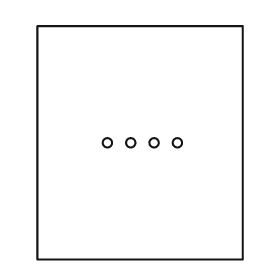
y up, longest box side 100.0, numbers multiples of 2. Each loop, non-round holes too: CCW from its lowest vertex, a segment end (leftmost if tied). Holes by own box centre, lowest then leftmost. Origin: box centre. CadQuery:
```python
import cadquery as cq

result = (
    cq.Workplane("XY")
    .moveTo(-44.0, -50.0)
    .lineTo(44.0, -50.0)
    .lineTo(44.0, 50.0)
    .lineTo(-44.0, 50.0)
    .close()
    .moveTo(-14.0, 0.0)
    .circle(2.0)
    .moveTo(-4.0, 0.0)
    .circle(2.0)
    .moveTo(6.0, 0.0)
    .circle(2.0)
    .moveTo(16.0, 0.0)
    .circle(2.0)
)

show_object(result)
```